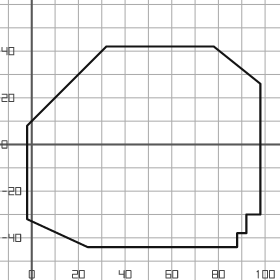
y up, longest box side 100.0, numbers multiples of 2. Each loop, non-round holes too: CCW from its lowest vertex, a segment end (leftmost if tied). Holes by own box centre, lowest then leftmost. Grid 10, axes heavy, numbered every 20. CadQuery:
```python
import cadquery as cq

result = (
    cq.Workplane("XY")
    .moveTo(24.0, -44.0)
    .lineTo(88.0, -44.0)
    .lineTo(88.0, -38.0)
    .lineTo(92.0, -38.0)
    .lineTo(92.0, -30.0)
    .lineTo(98.0, -30.0)
    .lineTo(98.0, 26.0)
    .lineTo(78.0, 42.0)
    .lineTo(32.0, 42.0)
    .lineTo(-2.0, 8.0)
    .lineTo(-2.0, -32.0)
    .close()
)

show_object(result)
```